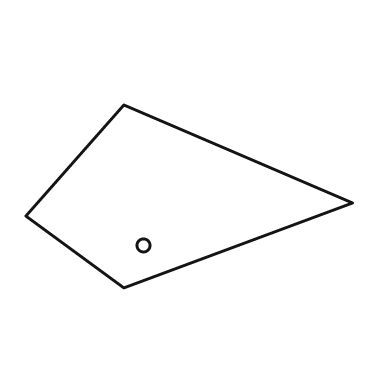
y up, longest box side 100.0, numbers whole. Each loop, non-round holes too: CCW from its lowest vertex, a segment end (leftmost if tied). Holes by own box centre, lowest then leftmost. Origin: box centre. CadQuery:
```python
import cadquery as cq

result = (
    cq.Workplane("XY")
    .moveTo(-20.0, -28.0)
    .lineTo(50.0, -2.0)
    .lineTo(-20.0, 28.0)
    .lineTo(-50.0, -6.0)
    .close()
    .moveTo(-14.0, -15.0)
    .circle(2.0)
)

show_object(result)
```